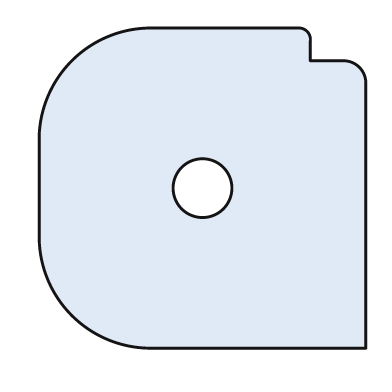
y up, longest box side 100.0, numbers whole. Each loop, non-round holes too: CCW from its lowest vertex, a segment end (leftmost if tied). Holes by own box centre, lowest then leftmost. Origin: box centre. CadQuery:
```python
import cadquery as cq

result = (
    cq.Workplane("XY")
    .moveTo(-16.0, -49.0)
    .lineTo(50.0, -49.0)
    .lineTo(50.0, 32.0)
    .threePointArc((48.0, 37.0), (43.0, 39.0))
    .lineTo(33.0, 39.0)
    .lineTo(33.0, 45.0)
    .threePointArc((32.0, 48.0), (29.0, 49.0))
    .lineTo(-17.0, 49.0)
    .threePointArc((-40.0, 39.0), (-50.0, 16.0))
    .lineTo(-50.0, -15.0)
    .threePointArc((-40.0, -39.0), (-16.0, -49.0))
    .close()
    .moveTo(0.0, 0.0)
    .circle(9.0)
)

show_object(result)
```